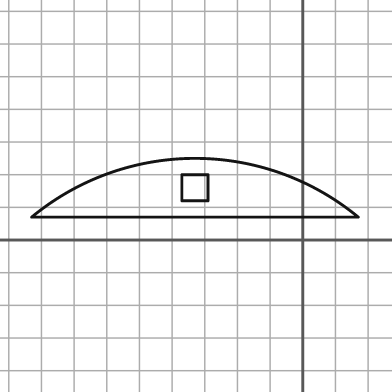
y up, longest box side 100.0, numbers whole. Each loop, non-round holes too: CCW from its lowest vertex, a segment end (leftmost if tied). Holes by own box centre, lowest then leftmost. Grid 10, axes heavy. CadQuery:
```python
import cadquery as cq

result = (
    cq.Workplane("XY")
    .moveTo(-83.0, 7.0)
    .lineTo(17.0, 7.0)
    .threePointArc((-33.0, 25.0), (-83.0, 7.0))
    .close()
    .moveTo(-37.0, 12.0)
    .lineTo(-29.0, 12.0)
    .lineTo(-29.0, 20.0)
    .lineTo(-37.0, 20.0)
    .close()
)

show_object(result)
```